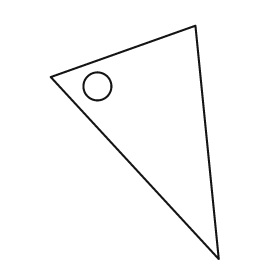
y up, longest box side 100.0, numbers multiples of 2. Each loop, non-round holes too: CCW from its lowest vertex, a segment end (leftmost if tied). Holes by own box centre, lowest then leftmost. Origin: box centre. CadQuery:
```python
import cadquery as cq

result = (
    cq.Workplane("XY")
    .moveTo(36.0, -50.0)
    .lineTo(26.0, 50.0)
    .lineTo(-36.0, 28.0)
    .close()
    .moveTo(-16.0, 24.0)
    .circle(6.0)
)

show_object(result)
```